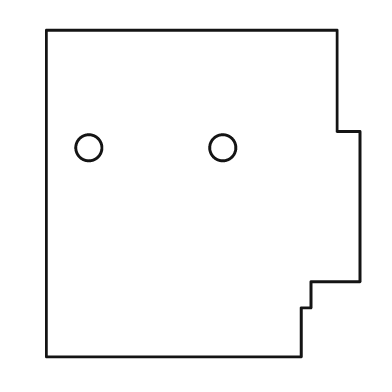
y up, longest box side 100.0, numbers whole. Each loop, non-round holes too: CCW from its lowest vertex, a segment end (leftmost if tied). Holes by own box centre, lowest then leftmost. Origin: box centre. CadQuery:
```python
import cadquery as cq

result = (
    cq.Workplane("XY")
    .moveTo(-48.0, -50.0)
    .lineTo(30.0, -50.0)
    .lineTo(30.0, -35.0)
    .lineTo(33.0, -35.0)
    .lineTo(33.0, -27.0)
    .lineTo(48.0, -27.0)
    .lineTo(48.0, 19.0)
    .lineTo(41.0, 19.0)
    .lineTo(41.0, 50.0)
    .lineTo(-48.0, 50.0)
    .close()
    .moveTo(-35.0, 14.0)
    .circle(4.0)
    .moveTo(6.0, 14.0)
    .circle(4.0)
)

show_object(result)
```